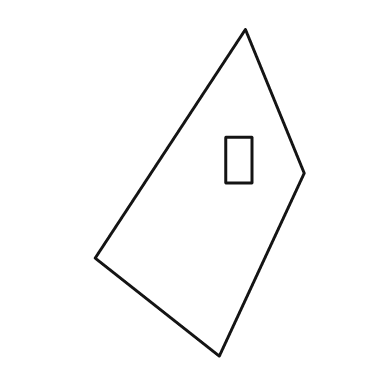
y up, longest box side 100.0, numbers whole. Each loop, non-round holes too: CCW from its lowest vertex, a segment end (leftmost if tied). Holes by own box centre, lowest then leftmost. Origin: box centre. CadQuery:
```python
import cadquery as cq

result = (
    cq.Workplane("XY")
    .moveTo(6.0, -50.0)
    .lineTo(32.0, 6.0)
    .lineTo(14.0, 50.0)
    .lineTo(-32.0, -20.0)
    .close()
    .moveTo(8.0, 3.0)
    .lineTo(16.0, 3.0)
    .lineTo(16.0, 17.0)
    .lineTo(8.0, 17.0)
    .close()
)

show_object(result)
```